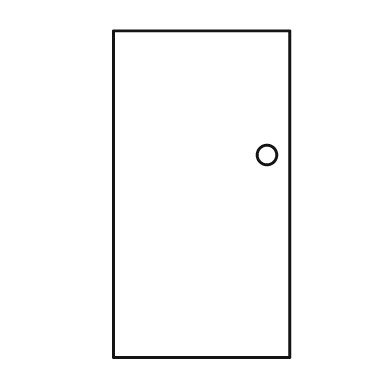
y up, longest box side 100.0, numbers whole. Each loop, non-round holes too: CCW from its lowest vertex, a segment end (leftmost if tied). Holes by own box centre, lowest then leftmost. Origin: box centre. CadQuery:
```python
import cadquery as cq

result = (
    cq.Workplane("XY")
    .moveTo(-27.0, -50.0)
    .lineTo(27.0, -50.0)
    .lineTo(27.0, 50.0)
    .lineTo(-27.0, 50.0)
    .close()
    .moveTo(20.0, 12.0)
    .circle(3.0)
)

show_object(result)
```